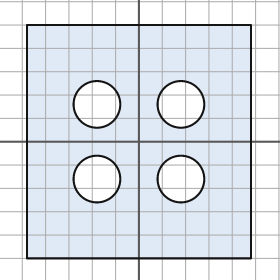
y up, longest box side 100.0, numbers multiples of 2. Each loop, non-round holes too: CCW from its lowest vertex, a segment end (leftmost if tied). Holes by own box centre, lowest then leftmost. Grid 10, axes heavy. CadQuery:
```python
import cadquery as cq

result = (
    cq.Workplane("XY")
    .moveTo(-48.0, -50.0)
    .lineTo(48.0, -50.0)
    .lineTo(48.0, 50.0)
    .lineTo(-48.0, 50.0)
    .close()
    .moveTo(-18.0, -16.0)
    .circle(10.0)
    .moveTo(18.0, -16.0)
    .circle(10.0)
    .moveTo(-18.0, 16.0)
    .circle(10.0)
    .moveTo(18.0, 16.0)
    .circle(10.0)
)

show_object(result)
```